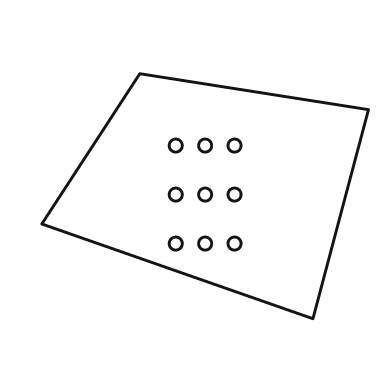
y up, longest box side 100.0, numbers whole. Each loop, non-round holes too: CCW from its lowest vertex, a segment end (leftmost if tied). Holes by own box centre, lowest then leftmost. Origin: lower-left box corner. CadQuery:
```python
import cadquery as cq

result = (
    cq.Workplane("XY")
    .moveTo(83.0, 0.0)
    .lineTo(100.0, 64.0)
    .lineTo(30.0, 75.0)
    .lineTo(0.0, 29.0)
    .close()
    .moveTo(41.0, 23.0)
    .circle(2.0)
    .moveTo(50.0, 23.0)
    .circle(2.0)
    .moveTo(59.0, 23.0)
    .circle(2.0)
    .moveTo(41.0, 38.0)
    .circle(2.0)
    .moveTo(50.0, 38.0)
    .circle(2.0)
    .moveTo(59.0, 38.0)
    .circle(2.0)
    .moveTo(41.0, 53.0)
    .circle(2.0)
    .moveTo(50.0, 53.0)
    .circle(2.0)
    .moveTo(59.0, 53.0)
    .circle(2.0)
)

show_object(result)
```